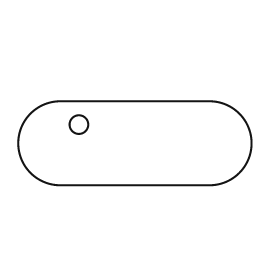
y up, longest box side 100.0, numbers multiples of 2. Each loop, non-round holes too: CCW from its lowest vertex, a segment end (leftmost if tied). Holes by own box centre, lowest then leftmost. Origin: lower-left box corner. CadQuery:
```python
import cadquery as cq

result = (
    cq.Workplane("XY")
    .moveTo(18.0, 0.0)
    .lineTo(82.0, 0.0)
    .threePointArc((100.0, 18.0), (82.0, 36.0))
    .lineTo(18.0, 36.0)
    .threePointArc((0.0, 18.0), (18.0, 0.0))
    .close()
    .moveTo(26.0, 26.0)
    .circle(4.0)
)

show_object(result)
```